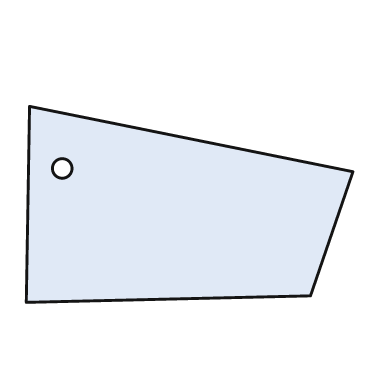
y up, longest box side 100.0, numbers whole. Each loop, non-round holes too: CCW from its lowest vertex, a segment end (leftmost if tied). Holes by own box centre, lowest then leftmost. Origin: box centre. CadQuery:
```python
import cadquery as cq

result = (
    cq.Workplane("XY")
    .moveTo(-50.0, -30.0)
    .lineTo(37.0, -28.0)
    .lineTo(50.0, 10.0)
    .lineTo(-49.0, 30.0)
    .close()
    .moveTo(-39.0, 11.0)
    .circle(3.0)
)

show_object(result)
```